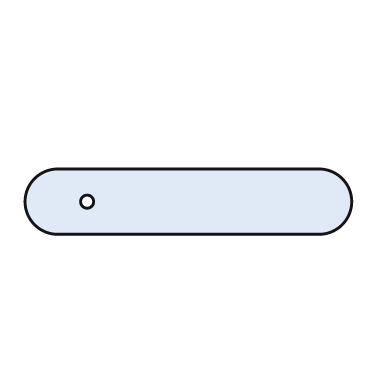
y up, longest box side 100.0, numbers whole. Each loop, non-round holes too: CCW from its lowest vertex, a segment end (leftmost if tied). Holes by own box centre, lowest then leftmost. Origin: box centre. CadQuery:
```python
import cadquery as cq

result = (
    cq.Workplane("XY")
    .moveTo(-40.0, -10.0)
    .lineTo(40.0, -10.0)
    .threePointArc((50.0, 0.0), (40.0, 10.0))
    .lineTo(-40.0, 10.0)
    .threePointArc((-50.0, 0.0), (-40.0, -10.0))
    .close()
    .moveTo(-31.0, 0.0)
    .circle(2.0)
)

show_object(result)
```